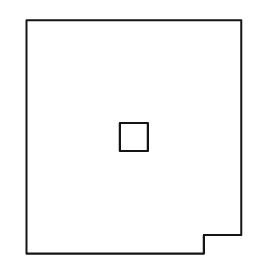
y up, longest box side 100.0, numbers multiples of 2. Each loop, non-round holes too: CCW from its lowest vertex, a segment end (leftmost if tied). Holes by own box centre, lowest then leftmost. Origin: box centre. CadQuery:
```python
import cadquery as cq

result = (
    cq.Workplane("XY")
    .moveTo(-46.0, -50.0)
    .lineTo(30.0, -50.0)
    .lineTo(30.0, -42.0)
    .lineTo(46.0, -42.0)
    .lineTo(46.0, 50.0)
    .lineTo(-46.0, 50.0)
    .close()
    .moveTo(-6.0, -6.0)
    .lineTo(6.0, -6.0)
    .lineTo(6.0, 6.0)
    .lineTo(-6.0, 6.0)
    .close()
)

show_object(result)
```